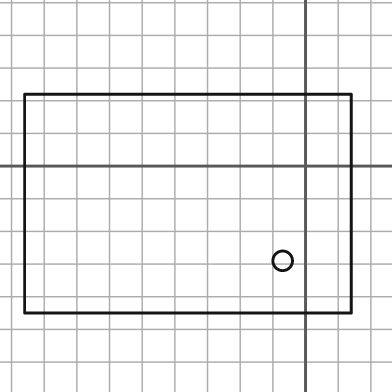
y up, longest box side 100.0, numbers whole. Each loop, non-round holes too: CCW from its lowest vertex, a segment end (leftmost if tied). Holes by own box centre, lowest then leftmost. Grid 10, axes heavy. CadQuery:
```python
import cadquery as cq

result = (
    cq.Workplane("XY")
    .moveTo(-86.0, -45.0)
    .lineTo(14.0, -45.0)
    .lineTo(14.0, 22.0)
    .lineTo(-86.0, 22.0)
    .close()
    .moveTo(-7.0, -29.0)
    .circle(3.0)
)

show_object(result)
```